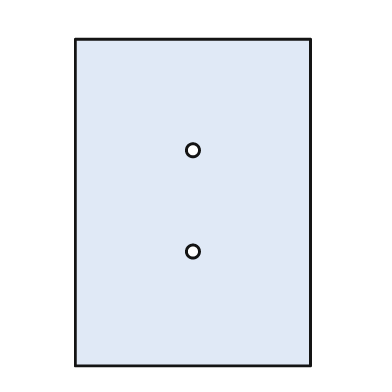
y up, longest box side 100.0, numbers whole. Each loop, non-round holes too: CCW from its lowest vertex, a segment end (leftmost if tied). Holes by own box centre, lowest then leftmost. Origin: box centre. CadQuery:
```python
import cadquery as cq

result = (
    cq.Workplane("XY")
    .moveTo(-36.0, -50.0)
    .lineTo(36.0, -50.0)
    .lineTo(36.0, 50.0)
    .lineTo(-36.0, 50.0)
    .close()
    .moveTo(0.0, -15.0)
    .circle(2.0)
    .moveTo(0.0, 16.0)
    .circle(2.0)
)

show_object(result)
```